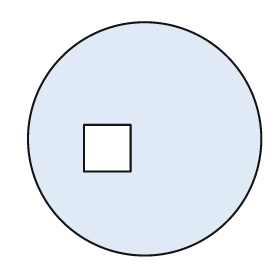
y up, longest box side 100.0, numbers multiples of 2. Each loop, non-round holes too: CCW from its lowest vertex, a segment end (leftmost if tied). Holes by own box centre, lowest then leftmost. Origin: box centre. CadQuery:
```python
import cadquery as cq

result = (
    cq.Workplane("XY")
    .moveTo(0.0, 0.0)
    .circle(50.0)
    .moveTo(-26.0, -14.0)
    .lineTo(-6.0, -14.0)
    .lineTo(-6.0, 6.0)
    .lineTo(-26.0, 6.0)
    .close()
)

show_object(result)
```